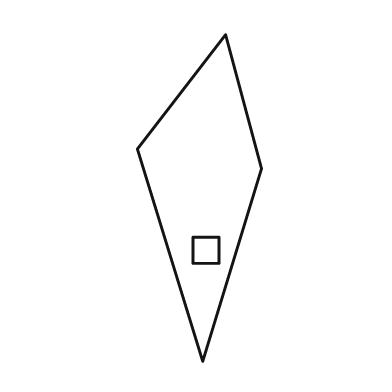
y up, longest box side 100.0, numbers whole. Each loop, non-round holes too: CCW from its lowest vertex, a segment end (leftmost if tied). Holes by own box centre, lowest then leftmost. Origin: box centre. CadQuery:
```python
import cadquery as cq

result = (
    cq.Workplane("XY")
    .moveTo(1.0, -50.0)
    .lineTo(19.0, 9.0)
    .lineTo(8.0, 50.0)
    .lineTo(-19.0, 15.0)
    .close()
    .moveTo(-2.0, -20.0)
    .lineTo(6.0, -20.0)
    .lineTo(6.0, -12.0)
    .lineTo(-2.0, -12.0)
    .close()
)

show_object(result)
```